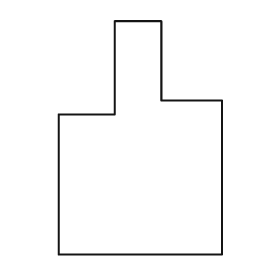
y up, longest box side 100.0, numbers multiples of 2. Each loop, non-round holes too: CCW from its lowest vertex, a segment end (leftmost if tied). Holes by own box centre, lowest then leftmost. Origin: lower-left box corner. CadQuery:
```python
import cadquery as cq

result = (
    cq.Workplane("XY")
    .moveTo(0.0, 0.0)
    .lineTo(70.0, 0.0)
    .lineTo(70.0, 66.0)
    .lineTo(44.0, 66.0)
    .lineTo(44.0, 100.0)
    .lineTo(24.0, 100.0)
    .lineTo(24.0, 60.0)
    .lineTo(0.0, 60.0)
    .close()
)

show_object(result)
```